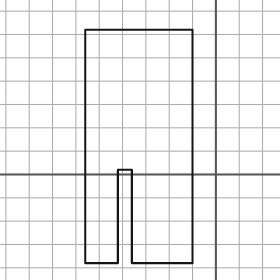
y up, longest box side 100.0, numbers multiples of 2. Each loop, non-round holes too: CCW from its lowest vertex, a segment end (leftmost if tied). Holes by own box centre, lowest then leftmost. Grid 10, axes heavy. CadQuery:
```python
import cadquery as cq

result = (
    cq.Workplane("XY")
    .moveTo(-56.0, -38.0)
    .lineTo(-42.0, -38.0)
    .lineTo(-42.0, 2.0)
    .lineTo(-36.0, 2.0)
    .lineTo(-36.0, -38.0)
    .lineTo(-10.0, -38.0)
    .lineTo(-10.0, 62.0)
    .lineTo(-56.0, 62.0)
    .close()
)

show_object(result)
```